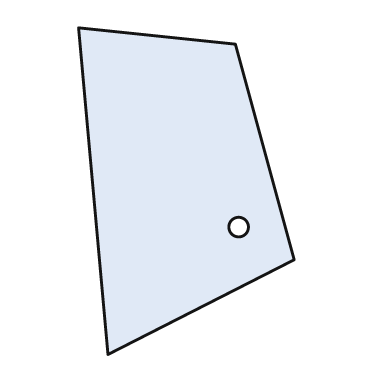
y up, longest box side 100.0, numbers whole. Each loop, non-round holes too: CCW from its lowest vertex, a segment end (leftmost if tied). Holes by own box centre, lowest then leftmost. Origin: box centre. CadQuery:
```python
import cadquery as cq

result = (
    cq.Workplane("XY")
    .moveTo(-24.0, -50.0)
    .lineTo(33.0, -21.0)
    .lineTo(15.0, 45.0)
    .lineTo(-33.0, 50.0)
    .close()
    .moveTo(16.0, -11.0)
    .circle(3.0)
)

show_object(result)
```